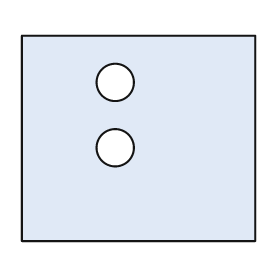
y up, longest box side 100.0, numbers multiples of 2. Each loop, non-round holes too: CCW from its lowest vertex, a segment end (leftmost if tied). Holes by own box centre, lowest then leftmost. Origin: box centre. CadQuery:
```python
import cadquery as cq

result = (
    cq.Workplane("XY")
    .moveTo(-50.0, -44.0)
    .lineTo(50.0, -44.0)
    .lineTo(50.0, 44.0)
    .lineTo(-50.0, 44.0)
    .close()
    .moveTo(-10.0, -4.0)
    .circle(8.0)
    .moveTo(-10.0, 24.0)
    .circle(8.0)
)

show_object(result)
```